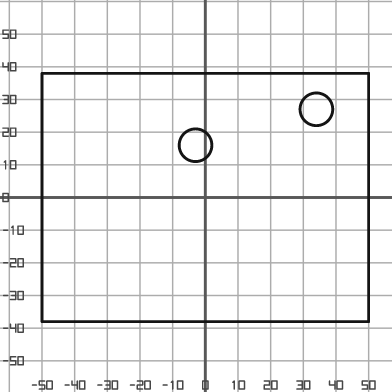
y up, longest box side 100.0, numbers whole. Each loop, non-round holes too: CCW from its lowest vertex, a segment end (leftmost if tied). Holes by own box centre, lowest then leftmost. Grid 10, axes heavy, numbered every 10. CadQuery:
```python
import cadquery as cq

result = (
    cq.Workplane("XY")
    .moveTo(-50.0, -38.0)
    .lineTo(50.0, -38.0)
    .lineTo(50.0, 38.0)
    .lineTo(-50.0, 38.0)
    .close()
    .moveTo(-3.0, 16.0)
    .circle(5.0)
    .moveTo(34.0, 27.0)
    .circle(5.0)
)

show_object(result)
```